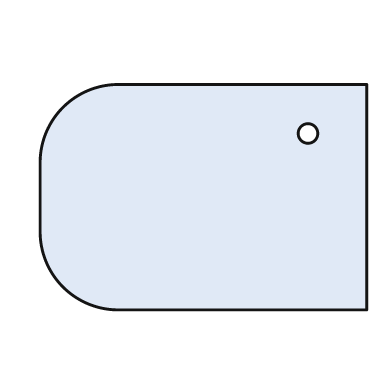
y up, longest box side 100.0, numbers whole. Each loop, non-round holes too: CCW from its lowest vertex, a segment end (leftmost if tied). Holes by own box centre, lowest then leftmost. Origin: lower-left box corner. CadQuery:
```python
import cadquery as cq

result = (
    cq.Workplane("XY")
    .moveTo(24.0, 0.0)
    .lineTo(100.0, 0.0)
    .lineTo(100.0, 69.0)
    .lineTo(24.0, 69.0)
    .threePointArc((7.0, 62.0), (0.0, 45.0))
    .lineTo(0.0, 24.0)
    .threePointArc((7.0, 7.0), (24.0, 0.0))
    .close()
    .moveTo(82.0, 54.0)
    .circle(3.0)
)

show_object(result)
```